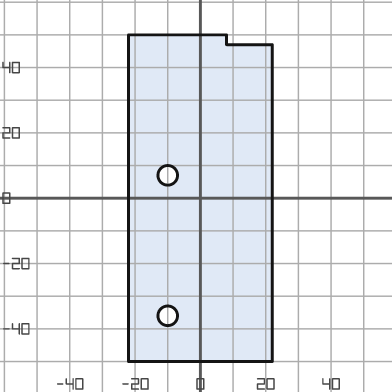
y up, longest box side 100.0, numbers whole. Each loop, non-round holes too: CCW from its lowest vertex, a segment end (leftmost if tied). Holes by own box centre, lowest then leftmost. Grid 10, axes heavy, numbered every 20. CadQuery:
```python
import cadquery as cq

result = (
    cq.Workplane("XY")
    .moveTo(-22.0, -50.0)
    .lineTo(22.0, -50.0)
    .lineTo(22.0, 47.0)
    .lineTo(8.0, 47.0)
    .lineTo(8.0, 50.0)
    .lineTo(-22.0, 50.0)
    .close()
    .moveTo(-10.0, -36.0)
    .circle(3.0)
    .moveTo(-10.0, 7.0)
    .circle(3.0)
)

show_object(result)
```